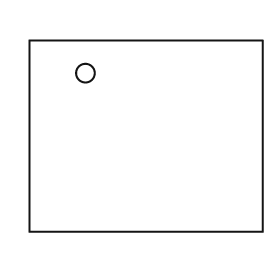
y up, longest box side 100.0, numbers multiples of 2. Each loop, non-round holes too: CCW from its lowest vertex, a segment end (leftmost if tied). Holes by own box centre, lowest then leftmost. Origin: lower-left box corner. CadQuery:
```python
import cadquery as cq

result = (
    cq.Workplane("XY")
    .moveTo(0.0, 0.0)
    .lineTo(100.0, 0.0)
    .lineTo(100.0, 82.0)
    .lineTo(0.0, 82.0)
    .close()
    .moveTo(24.0, 68.0)
    .circle(4.0)
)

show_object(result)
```